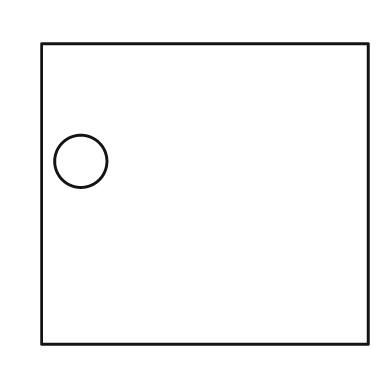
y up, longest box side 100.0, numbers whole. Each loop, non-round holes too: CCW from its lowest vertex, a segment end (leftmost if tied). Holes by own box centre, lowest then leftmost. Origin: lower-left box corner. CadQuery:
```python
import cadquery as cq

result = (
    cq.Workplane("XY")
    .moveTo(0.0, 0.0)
    .lineTo(100.0, 0.0)
    .lineTo(100.0, 92.0)
    .lineTo(0.0, 92.0)
    .close()
    .moveTo(12.0, 56.0)
    .circle(8.0)
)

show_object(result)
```